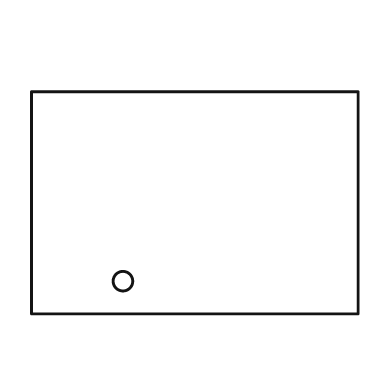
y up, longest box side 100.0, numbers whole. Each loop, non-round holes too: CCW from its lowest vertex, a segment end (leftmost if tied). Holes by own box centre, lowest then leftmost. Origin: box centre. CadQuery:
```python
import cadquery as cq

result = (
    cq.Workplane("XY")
    .moveTo(-50.0, -34.0)
    .lineTo(50.0, -34.0)
    .lineTo(50.0, 34.0)
    .lineTo(-50.0, 34.0)
    .close()
    .moveTo(-22.0, -24.0)
    .circle(3.0)
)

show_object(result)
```